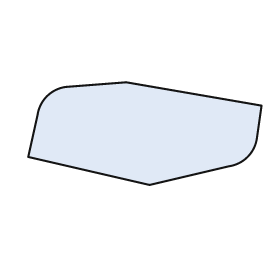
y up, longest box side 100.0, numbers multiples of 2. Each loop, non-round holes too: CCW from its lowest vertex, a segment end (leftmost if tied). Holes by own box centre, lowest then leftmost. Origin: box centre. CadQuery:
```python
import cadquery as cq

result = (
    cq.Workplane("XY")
    .moveTo(2.0, -22.0)
    .lineTo(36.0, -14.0)
    .threePointArc((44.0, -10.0), (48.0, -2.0))
    .lineTo(50.0, 12.0)
    .lineTo(-8.0, 22.0)
    .lineTo(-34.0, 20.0)
    .threePointArc((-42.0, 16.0), (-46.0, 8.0))
    .lineTo(-50.0, -10.0)
    .close()
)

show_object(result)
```